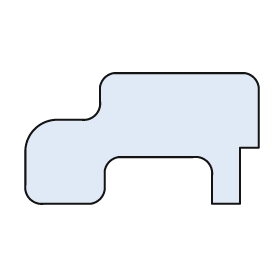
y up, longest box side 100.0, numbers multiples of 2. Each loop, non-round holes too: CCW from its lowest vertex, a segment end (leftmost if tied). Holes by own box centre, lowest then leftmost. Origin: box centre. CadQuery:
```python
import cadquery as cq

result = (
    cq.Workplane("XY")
    .moveTo(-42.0, -28.0)
    .lineTo(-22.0, -28.0)
    .threePointArc((-18.0, -26.0), (-16.0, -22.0))
    .lineTo(-16.0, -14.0)
    .threePointArc((-14.0, -10.0), (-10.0, -8.0))
    .lineTo(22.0, -8.0)
    .threePointArc((28.0, -10.0), (30.0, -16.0))
    .lineTo(30.0, -28.0)
    .lineTo(42.0, -28.0)
    .lineTo(42.0, -4.0)
    .lineTo(50.0, -4.0)
    .lineTo(50.0, 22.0)
    .threePointArc((48.0, 26.0), (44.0, 28.0))
    .lineTo(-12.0, 28.0)
    .threePointArc((-16.0, 26.0), (-18.0, 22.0))
    .lineTo(-18.0, 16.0)
    .threePointArc((-20.0, 10.0), (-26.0, 8.0))
    .lineTo(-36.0, 8.0)
    .threePointArc((-46.0, 4.0), (-50.0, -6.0))
    .lineTo(-50.0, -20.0)
    .threePointArc((-48.0, -26.0), (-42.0, -28.0))
    .close()
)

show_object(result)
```